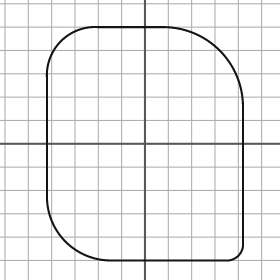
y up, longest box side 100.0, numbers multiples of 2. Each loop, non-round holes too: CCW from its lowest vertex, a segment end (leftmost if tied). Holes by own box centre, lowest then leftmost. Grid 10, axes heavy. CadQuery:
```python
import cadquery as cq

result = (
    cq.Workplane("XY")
    .moveTo(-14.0, -50.0)
    .lineTo(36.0, -50.0)
    .threePointArc((40.0, -48.0), (42.0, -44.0))
    .lineTo(42.0, 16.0)
    .threePointArc((32.0, 40.0), (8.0, 50.0))
    .lineTo(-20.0, 50.0)
    .threePointArc((-36.0, 44.0), (-42.0, 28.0))
    .lineTo(-42.0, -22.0)
    .threePointArc((-34.0, -42.0), (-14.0, -50.0))
    .close()
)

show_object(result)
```